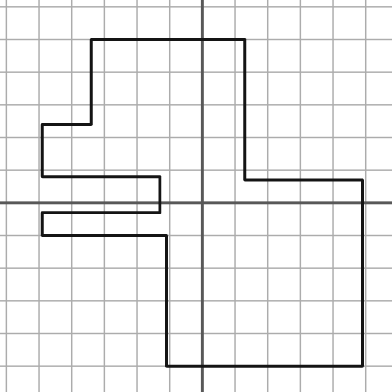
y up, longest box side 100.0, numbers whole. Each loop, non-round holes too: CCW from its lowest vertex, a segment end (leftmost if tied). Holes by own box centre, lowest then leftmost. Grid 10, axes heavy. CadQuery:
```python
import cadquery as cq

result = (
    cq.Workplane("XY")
    .moveTo(-11.0, -50.0)
    .lineTo(49.0, -50.0)
    .lineTo(49.0, 7.0)
    .lineTo(13.0, 7.0)
    .lineTo(13.0, 50.0)
    .lineTo(-34.0, 50.0)
    .lineTo(-34.0, 24.0)
    .lineTo(-49.0, 24.0)
    .lineTo(-49.0, 8.0)
    .lineTo(-13.0, 8.0)
    .lineTo(-13.0, -3.0)
    .lineTo(-49.0, -3.0)
    .lineTo(-49.0, -10.0)
    .lineTo(-11.0, -10.0)
    .close()
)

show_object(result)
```